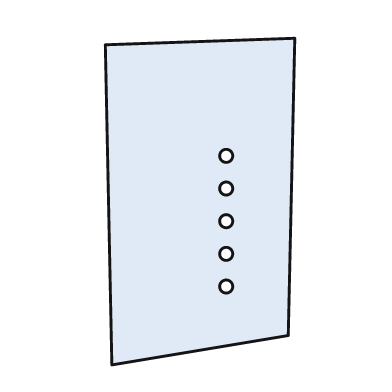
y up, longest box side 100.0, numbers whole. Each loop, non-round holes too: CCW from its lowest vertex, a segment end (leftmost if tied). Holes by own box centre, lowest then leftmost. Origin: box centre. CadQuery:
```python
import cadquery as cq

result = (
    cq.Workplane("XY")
    .moveTo(-27.0, -50.0)
    .lineTo(27.0, -41.0)
    .lineTo(29.0, 50.0)
    .lineTo(-29.0, 48.0)
    .close()
    .moveTo(8.0, -26.0)
    .circle(2.0)
    .moveTo(8.0, -16.0)
    .circle(2.0)
    .moveTo(8.0, -6.0)
    .circle(2.0)
    .moveTo(8.0, 4.0)
    .circle(2.0)
    .moveTo(8.0, 14.0)
    .circle(2.0)
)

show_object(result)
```